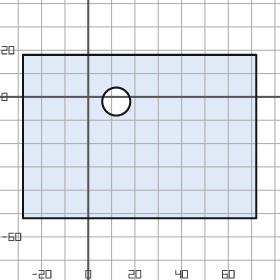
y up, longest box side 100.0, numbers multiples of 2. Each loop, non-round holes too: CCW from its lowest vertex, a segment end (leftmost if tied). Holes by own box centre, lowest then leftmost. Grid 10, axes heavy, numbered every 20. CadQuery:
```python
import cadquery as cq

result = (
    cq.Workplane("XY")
    .moveTo(-28.0, -52.0)
    .lineTo(72.0, -52.0)
    .lineTo(72.0, 18.0)
    .lineTo(-28.0, 18.0)
    .close()
    .moveTo(12.0, -2.0)
    .circle(6.0)
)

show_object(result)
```